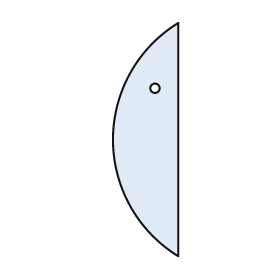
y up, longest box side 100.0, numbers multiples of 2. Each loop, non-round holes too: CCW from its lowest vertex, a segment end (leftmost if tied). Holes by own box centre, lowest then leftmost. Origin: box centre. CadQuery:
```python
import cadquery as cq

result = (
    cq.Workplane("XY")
    .moveTo(14.0, -50.0)
    .lineTo(14.0, 50.0)
    .threePointArc((-14.0, 0.0), (14.0, -50.0))
    .close()
    .moveTo(4.0, 22.0)
    .circle(2.0)
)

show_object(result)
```